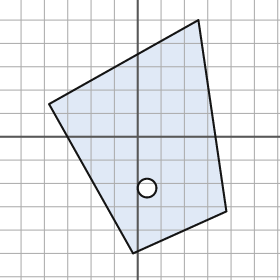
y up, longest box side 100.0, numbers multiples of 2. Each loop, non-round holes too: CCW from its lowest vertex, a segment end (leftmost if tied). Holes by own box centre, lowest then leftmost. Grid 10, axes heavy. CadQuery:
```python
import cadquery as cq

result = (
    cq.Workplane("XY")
    .moveTo(-2.0, -50.0)
    .lineTo(38.0, -32.0)
    .lineTo(26.0, 50.0)
    .lineTo(-38.0, 14.0)
    .close()
    .moveTo(4.0, -22.0)
    .circle(4.0)
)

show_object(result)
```